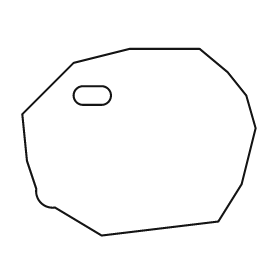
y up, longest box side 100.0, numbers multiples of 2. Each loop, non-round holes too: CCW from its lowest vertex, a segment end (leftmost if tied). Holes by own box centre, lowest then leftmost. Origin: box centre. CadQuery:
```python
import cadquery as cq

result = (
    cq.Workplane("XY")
    .moveTo(-16.0, -40.0)
    .lineTo(34.0, -34.0)
    .lineTo(44.0, -18.0)
    .lineTo(50.0, 6.0)
    .lineTo(46.0, 20.0)
    .lineTo(38.0, 30.0)
    .lineTo(26.0, 40.0)
    .lineTo(-4.0, 40.0)
    .lineTo(-28.0, 34.0)
    .lineTo(-50.0, 12.0)
    .lineTo(-48.0, -8.0)
    .lineTo(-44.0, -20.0)
    .threePointArc((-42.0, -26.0), (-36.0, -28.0))
    .close()
    .moveTo(-24.0, 16.0)
    .lineTo(-16.0, 16.0)
    .threePointArc((-12.0, 20.0), (-16.0, 24.0))
    .lineTo(-24.0, 24.0)
    .threePointArc((-28.0, 20.0), (-24.0, 16.0))
    .close()
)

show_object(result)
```